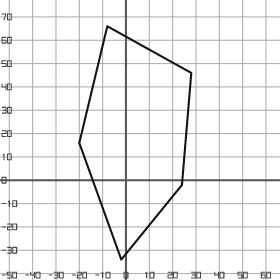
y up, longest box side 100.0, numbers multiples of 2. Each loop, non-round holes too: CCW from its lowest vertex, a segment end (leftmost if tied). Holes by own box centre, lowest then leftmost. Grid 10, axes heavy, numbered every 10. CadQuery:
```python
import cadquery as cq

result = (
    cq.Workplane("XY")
    .moveTo(-2.0, -34.0)
    .lineTo(24.0, -2.0)
    .lineTo(28.0, 46.0)
    .lineTo(-8.0, 66.0)
    .lineTo(-20.0, 16.0)
    .close()
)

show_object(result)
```